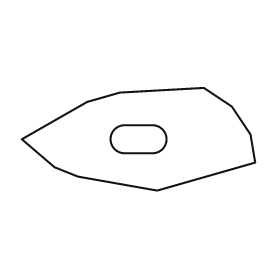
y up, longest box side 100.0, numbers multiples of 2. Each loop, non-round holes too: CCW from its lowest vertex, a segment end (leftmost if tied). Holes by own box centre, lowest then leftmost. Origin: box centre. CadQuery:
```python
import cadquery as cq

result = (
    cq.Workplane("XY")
    .moveTo(8.0, -22.0)
    .lineTo(50.0, -10.0)
    .lineTo(48.0, 2.0)
    .lineTo(40.0, 14.0)
    .lineTo(28.0, 22.0)
    .lineTo(-8.0, 20.0)
    .lineTo(-22.0, 16.0)
    .lineTo(-50.0, 0.0)
    .lineTo(-36.0, -12.0)
    .lineTo(-26.0, -16.0)
    .close()
    .moveTo(-6.0, -6.0)
    .lineTo(6.0, -6.0)
    .threePointArc((12.0, 0.0), (6.0, 6.0))
    .lineTo(-6.0, 6.0)
    .threePointArc((-12.0, 0.0), (-6.0, -6.0))
    .close()
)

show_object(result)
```